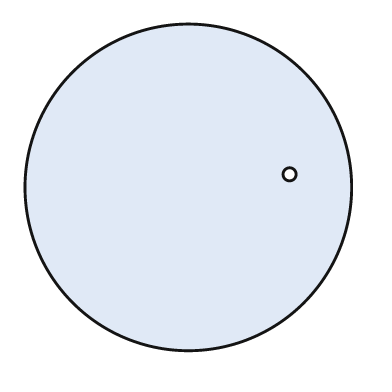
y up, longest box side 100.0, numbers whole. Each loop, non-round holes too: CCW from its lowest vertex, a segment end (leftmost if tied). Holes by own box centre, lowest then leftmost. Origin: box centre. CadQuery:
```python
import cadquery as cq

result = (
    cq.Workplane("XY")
    .moveTo(0.0, 0.0)
    .circle(50.0)
    .moveTo(31.0, 4.0)
    .circle(2.0)
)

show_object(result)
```